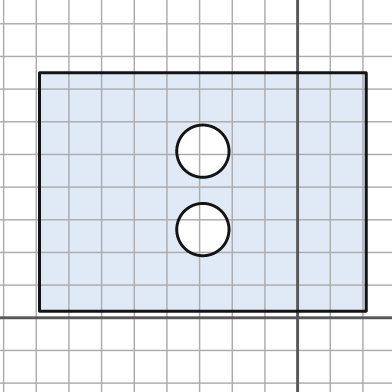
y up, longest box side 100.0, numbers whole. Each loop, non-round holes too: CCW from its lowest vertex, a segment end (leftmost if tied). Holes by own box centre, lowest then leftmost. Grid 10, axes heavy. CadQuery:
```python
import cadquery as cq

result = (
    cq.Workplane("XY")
    .moveTo(-79.0, 2.0)
    .lineTo(21.0, 2.0)
    .lineTo(21.0, 75.0)
    .lineTo(-79.0, 75.0)
    .close()
    .moveTo(-29.0, 27.0)
    .circle(8.0)
    .moveTo(-29.0, 51.0)
    .circle(8.0)
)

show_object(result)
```